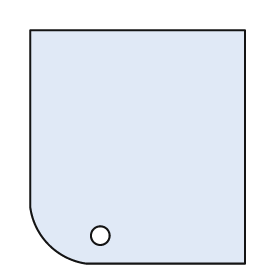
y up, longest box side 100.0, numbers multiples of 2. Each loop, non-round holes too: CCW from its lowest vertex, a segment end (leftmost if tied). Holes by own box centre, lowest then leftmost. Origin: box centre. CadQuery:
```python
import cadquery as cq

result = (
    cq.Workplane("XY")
    .moveTo(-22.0, -50.0)
    .lineTo(46.0, -50.0)
    .lineTo(46.0, 50.0)
    .lineTo(-46.0, 50.0)
    .lineTo(-46.0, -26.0)
    .threePointArc((-38.0, -42.0), (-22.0, -50.0))
    .close()
    .moveTo(-16.0, -38.0)
    .circle(4.0)
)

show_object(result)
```